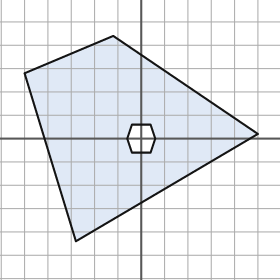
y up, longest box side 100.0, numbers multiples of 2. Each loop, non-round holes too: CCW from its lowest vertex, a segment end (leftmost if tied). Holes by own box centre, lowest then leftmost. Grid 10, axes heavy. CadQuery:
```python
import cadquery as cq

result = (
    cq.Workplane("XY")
    .moveTo(-28.0, -44.0)
    .lineTo(50.0, 2.0)
    .lineTo(-12.0, 44.0)
    .lineTo(-50.0, 28.0)
    .close()
    .moveTo(-4.0, -6.0)
    .lineTo(4.0, -6.0)
    .lineTo(6.0, 0.0)
    .lineTo(4.0, 6.0)
    .lineTo(-4.0, 6.0)
    .lineTo(-6.0, 0.0)
    .close()
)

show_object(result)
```